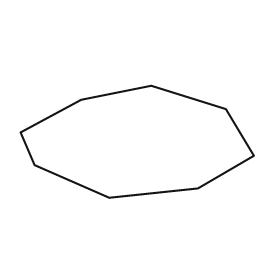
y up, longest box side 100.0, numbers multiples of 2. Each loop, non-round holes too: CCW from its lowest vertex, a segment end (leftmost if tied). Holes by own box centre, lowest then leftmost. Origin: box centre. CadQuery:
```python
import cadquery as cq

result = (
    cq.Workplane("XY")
    .moveTo(-12.0, -24.0)
    .lineTo(26.0, -20.0)
    .lineTo(50.0, -6.0)
    .lineTo(38.0, 14.0)
    .lineTo(6.0, 24.0)
    .lineTo(-24.0, 18.0)
    .lineTo(-50.0, 4.0)
    .lineTo(-44.0, -10.0)
    .close()
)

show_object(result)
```